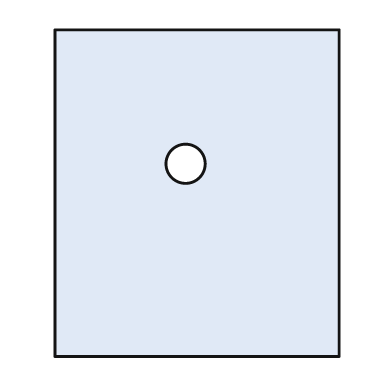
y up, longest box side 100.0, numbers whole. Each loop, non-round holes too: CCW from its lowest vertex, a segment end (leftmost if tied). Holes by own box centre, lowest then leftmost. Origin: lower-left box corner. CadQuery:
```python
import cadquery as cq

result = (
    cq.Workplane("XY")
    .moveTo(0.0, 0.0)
    .lineTo(87.0, 0.0)
    .lineTo(87.0, 100.0)
    .lineTo(0.0, 100.0)
    .close()
    .moveTo(40.0, 59.0)
    .circle(6.0)
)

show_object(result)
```